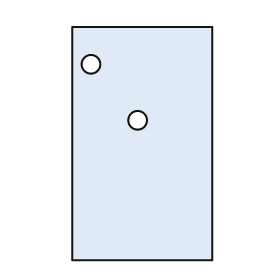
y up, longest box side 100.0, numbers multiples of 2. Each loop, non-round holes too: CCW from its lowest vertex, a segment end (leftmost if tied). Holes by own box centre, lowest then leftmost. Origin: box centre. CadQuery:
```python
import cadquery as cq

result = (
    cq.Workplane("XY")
    .moveTo(-30.0, -50.0)
    .lineTo(30.0, -50.0)
    .lineTo(30.0, 50.0)
    .lineTo(-30.0, 50.0)
    .close()
    .moveTo(-2.0, 10.0)
    .circle(4.0)
    .moveTo(-22.0, 34.0)
    .circle(4.0)
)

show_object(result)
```